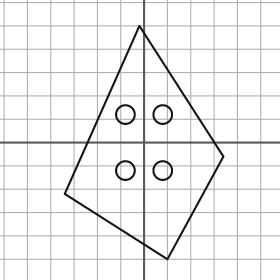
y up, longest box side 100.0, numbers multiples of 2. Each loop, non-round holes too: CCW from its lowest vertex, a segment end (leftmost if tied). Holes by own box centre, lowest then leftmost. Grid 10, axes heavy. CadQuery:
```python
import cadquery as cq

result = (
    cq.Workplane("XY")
    .moveTo(10.0, -50.0)
    .lineTo(34.0, -6.0)
    .lineTo(-2.0, 50.0)
    .lineTo(-34.0, -22.0)
    .close()
    .moveTo(-8.0, -12.0)
    .circle(4.0)
    .moveTo(8.0, -12.0)
    .circle(4.0)
    .moveTo(-8.0, 12.0)
    .circle(4.0)
    .moveTo(8.0, 12.0)
    .circle(4.0)
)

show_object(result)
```